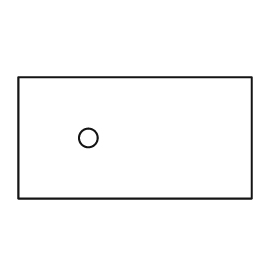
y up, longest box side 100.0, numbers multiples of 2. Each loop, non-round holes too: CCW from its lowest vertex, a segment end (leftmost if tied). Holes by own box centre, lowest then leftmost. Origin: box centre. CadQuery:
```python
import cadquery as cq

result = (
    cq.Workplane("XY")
    .moveTo(-50.0, -26.0)
    .lineTo(50.0, -26.0)
    .lineTo(50.0, 26.0)
    .lineTo(-50.0, 26.0)
    .close()
    .moveTo(-20.0, 0.0)
    .circle(4.0)
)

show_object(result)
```